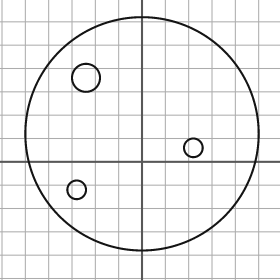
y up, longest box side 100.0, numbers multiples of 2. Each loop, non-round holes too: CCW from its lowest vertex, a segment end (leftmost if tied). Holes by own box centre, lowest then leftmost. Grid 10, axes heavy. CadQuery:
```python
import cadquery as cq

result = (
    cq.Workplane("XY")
    .moveTo(0.0, 12.0)
    .circle(50.0)
    .moveTo(-28.0, -12.0)
    .circle(4.0)
    .moveTo(22.0, 6.0)
    .circle(4.0)
    .moveTo(-24.0, 36.0)
    .circle(6.0)
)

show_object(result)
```